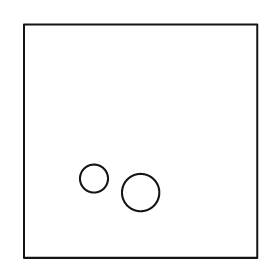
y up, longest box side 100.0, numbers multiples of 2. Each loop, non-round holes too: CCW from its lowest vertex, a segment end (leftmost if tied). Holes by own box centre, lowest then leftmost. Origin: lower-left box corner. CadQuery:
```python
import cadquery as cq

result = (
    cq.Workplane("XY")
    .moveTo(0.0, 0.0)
    .lineTo(100.0, 0.0)
    .lineTo(100.0, 100.0)
    .lineTo(0.0, 100.0)
    .close()
    .moveTo(50.0, 28.0)
    .circle(8.0)
    .moveTo(30.0, 34.0)
    .circle(6.0)
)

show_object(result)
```